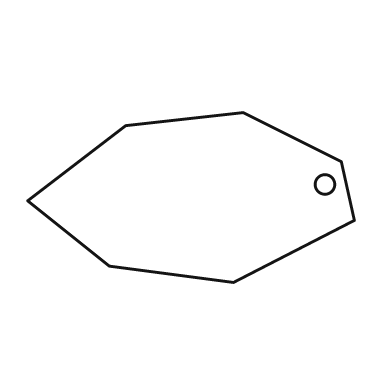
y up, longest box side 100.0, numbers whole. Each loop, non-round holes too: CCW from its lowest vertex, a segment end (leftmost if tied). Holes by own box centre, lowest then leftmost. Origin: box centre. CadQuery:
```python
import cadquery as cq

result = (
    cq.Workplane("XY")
    .moveTo(13.0, -26.0)
    .lineTo(50.0, -7.0)
    .lineTo(46.0, 11.0)
    .lineTo(16.0, 26.0)
    .lineTo(-20.0, 22.0)
    .lineTo(-50.0, -1.0)
    .lineTo(-25.0, -21.0)
    .close()
    .moveTo(41.0, 4.0)
    .circle(3.0)
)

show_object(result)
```